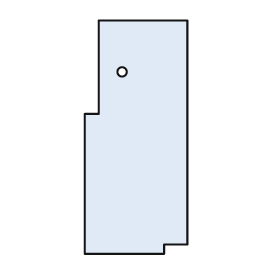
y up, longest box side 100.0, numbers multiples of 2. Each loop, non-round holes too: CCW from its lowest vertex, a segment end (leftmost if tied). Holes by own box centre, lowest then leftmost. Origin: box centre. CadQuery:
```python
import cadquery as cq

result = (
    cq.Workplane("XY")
    .moveTo(-22.0, -50.0)
    .lineTo(12.0, -50.0)
    .lineTo(12.0, -46.0)
    .lineTo(22.0, -46.0)
    .lineTo(22.0, 50.0)
    .lineTo(-16.0, 50.0)
    .lineTo(-16.0, 10.0)
    .lineTo(-22.0, 10.0)
    .close()
    .moveTo(-6.0, 28.0)
    .circle(2.0)
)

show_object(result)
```